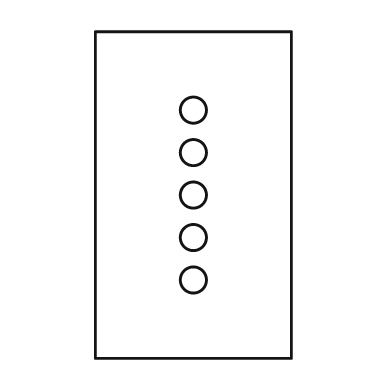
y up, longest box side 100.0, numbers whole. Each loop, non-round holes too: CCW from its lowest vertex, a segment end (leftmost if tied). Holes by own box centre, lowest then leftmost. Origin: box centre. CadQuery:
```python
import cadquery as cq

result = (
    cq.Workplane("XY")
    .moveTo(-30.0, -50.0)
    .lineTo(30.0, -50.0)
    .lineTo(30.0, 50.0)
    .lineTo(-30.0, 50.0)
    .close()
    .moveTo(0.0, -26.0)
    .circle(4.0)
    .moveTo(0.0, -13.0)
    .circle(4.0)
    .moveTo(0.0, 0.0)
    .circle(4.0)
    .moveTo(0.0, 13.0)
    .circle(4.0)
    .moveTo(0.0, 26.0)
    .circle(4.0)
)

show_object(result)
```